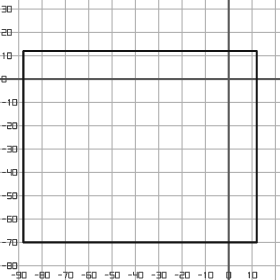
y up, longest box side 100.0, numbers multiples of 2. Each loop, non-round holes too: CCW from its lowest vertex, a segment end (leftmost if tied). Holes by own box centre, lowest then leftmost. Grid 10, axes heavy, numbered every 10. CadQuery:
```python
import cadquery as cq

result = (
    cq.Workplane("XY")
    .moveTo(-88.0, -70.0)
    .lineTo(12.0, -70.0)
    .lineTo(12.0, 12.0)
    .lineTo(-88.0, 12.0)
    .close()
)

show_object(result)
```